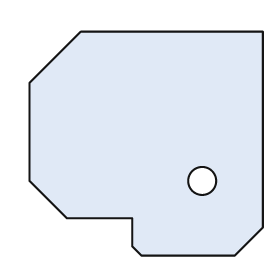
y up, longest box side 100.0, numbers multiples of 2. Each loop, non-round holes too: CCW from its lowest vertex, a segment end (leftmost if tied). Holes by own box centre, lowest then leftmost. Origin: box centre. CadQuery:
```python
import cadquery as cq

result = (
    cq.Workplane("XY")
    .moveTo(-2.0, -48.0)
    .lineTo(38.0, -48.0)
    .lineTo(50.0, -36.0)
    .lineTo(50.0, 48.0)
    .lineTo(-28.0, 48.0)
    .lineTo(-50.0, 26.0)
    .lineTo(-50.0, -16.0)
    .lineTo(-34.0, -32.0)
    .lineTo(-6.0, -32.0)
    .lineTo(-6.0, -44.0)
    .close()
    .moveTo(24.0, -16.0)
    .circle(6.0)
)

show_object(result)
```